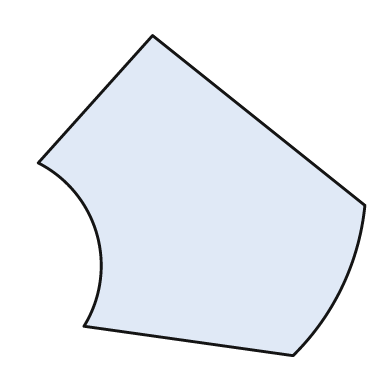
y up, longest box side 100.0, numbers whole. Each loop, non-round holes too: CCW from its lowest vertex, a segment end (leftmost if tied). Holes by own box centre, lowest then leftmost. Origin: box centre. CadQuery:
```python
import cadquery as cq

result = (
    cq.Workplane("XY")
    .moveTo(28.0, -49.0)
    .threePointArc((43.0, -28.0), (50.0, -3.0))
    .lineTo(-15.0, 49.0)
    .lineTo(-50.0, 10.0)
    .threePointArc((-32.0, -12.0), (-36.0, -40.0))
    .close()
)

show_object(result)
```